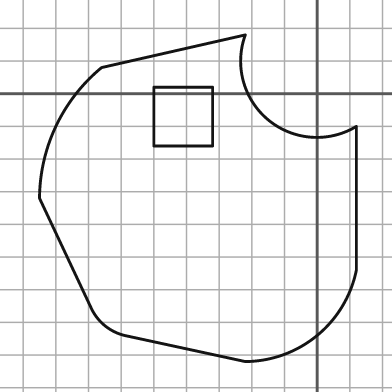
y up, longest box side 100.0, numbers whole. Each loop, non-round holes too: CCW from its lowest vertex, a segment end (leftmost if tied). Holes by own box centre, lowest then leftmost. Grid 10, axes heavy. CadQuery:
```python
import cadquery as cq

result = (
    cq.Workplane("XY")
    .moveTo(-22.0, -82.0)
    .threePointArc((0.0, -74.0), (12.0, -54.0))
    .lineTo(12.0, -10.0)
    .threePointArc((-15.0, -8.0), (-22.0, 18.0))
    .lineTo(-66.0, 8.0)
    .threePointArc((-80.0, -10.0), (-85.0, -32.0))
    .lineTo(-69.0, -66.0)
    .threePointArc((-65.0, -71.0), (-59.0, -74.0))
    .close()
    .moveTo(-50.0, -16.0)
    .lineTo(-32.0, -16.0)
    .lineTo(-32.0, 2.0)
    .lineTo(-50.0, 2.0)
    .close()
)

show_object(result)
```